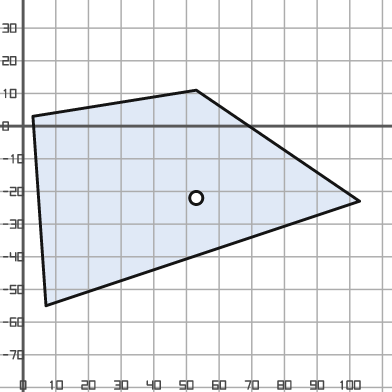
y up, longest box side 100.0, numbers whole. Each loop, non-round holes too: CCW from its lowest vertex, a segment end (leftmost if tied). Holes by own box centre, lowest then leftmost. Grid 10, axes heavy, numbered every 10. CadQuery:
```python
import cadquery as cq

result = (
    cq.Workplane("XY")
    .moveTo(7.0, -55.0)
    .lineTo(103.0, -23.0)
    .lineTo(53.0, 11.0)
    .lineTo(3.0, 3.0)
    .close()
    .moveTo(53.0, -22.0)
    .circle(2.0)
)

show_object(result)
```